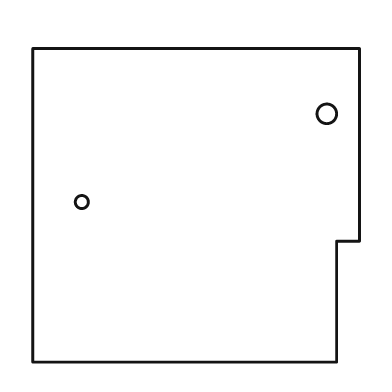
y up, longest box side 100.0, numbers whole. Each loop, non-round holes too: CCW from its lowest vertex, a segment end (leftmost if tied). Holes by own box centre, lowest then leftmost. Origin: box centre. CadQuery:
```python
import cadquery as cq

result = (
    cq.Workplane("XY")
    .moveTo(-50.0, -48.0)
    .lineTo(43.0, -48.0)
    .lineTo(43.0, -11.0)
    .lineTo(50.0, -11.0)
    .lineTo(50.0, 48.0)
    .lineTo(-50.0, 48.0)
    .close()
    .moveTo(-35.0, 1.0)
    .circle(2.0)
    .moveTo(40.0, 28.0)
    .circle(3.0)
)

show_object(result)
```